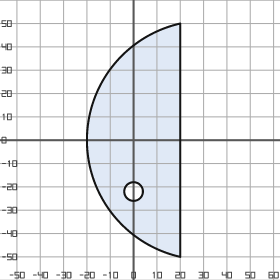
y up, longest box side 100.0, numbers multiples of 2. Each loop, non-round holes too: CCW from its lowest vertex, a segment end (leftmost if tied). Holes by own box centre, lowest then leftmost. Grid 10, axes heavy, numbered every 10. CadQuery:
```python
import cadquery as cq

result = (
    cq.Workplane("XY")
    .moveTo(20.0, -50.0)
    .lineTo(20.0, 50.0)
    .threePointArc((-20.0, 0.0), (20.0, -50.0))
    .close()
    .moveTo(0.0, -22.0)
    .circle(4.0)
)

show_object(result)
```